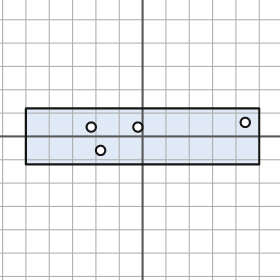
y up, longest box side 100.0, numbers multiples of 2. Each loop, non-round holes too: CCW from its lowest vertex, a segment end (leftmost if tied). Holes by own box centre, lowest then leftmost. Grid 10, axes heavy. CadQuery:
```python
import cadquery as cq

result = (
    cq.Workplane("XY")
    .moveTo(-50.0, -12.0)
    .lineTo(50.0, -12.0)
    .lineTo(50.0, 12.0)
    .lineTo(-50.0, 12.0)
    .close()
    .moveTo(-18.0, -6.0)
    .circle(2.0)
    .moveTo(-22.0, 4.0)
    .circle(2.0)
    .moveTo(-2.0, 4.0)
    .circle(2.0)
    .moveTo(44.0, 6.0)
    .circle(2.0)
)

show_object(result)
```